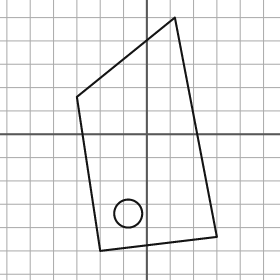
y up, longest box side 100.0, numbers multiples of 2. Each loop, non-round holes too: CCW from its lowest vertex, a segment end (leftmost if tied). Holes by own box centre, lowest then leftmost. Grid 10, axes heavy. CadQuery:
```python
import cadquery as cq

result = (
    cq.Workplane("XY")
    .moveTo(-20.0, -50.0)
    .lineTo(30.0, -44.0)
    .lineTo(12.0, 50.0)
    .lineTo(-30.0, 16.0)
    .close()
    .moveTo(-8.0, -34.0)
    .circle(6.0)
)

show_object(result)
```